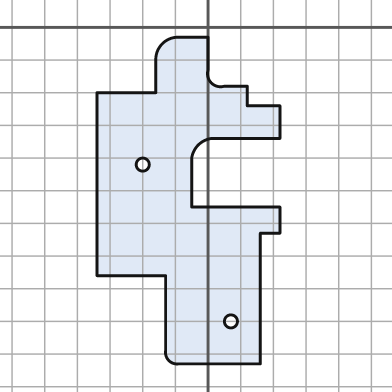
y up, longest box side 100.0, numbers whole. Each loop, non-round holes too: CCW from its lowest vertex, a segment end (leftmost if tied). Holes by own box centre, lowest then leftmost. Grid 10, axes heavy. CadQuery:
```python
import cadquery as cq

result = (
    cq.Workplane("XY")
    .moveTo(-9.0, -103.0)
    .lineTo(16.0, -103.0)
    .lineTo(16.0, -63.0)
    .lineTo(22.0, -63.0)
    .lineTo(22.0, -55.0)
    .lineTo(-5.0, -55.0)
    .lineTo(-5.0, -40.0)
    .threePointArc((-3.0, -36.0), (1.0, -34.0))
    .lineTo(22.0, -34.0)
    .lineTo(22.0, -24.0)
    .lineTo(12.0, -24.0)
    .lineTo(12.0, -18.0)
    .lineTo(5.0, -18.0)
    .threePointArc((1.0, -17.0), (0.0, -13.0))
    .lineTo(0.0, -3.0)
    .lineTo(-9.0, -3.0)
    .threePointArc((-14.0, -5.0), (-16.0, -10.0))
    .lineTo(-16.0, -20.0)
    .lineTo(-34.0, -20.0)
    .lineTo(-34.0, -76.0)
    .lineTo(-13.0, -76.0)
    .lineTo(-13.0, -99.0)
    .threePointArc((-12.0, -102.0), (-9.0, -103.0))
    .close()
    .moveTo(7.0, -90.0)
    .circle(2.0)
    .moveTo(-20.0, -42.0)
    .circle(2.0)
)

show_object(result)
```